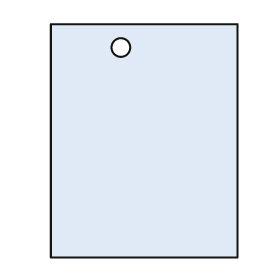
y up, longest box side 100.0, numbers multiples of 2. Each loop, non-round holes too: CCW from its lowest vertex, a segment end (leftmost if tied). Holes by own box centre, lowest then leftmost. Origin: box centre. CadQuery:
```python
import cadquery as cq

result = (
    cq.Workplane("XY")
    .moveTo(-40.0, -50.0)
    .lineTo(40.0, -50.0)
    .lineTo(40.0, 50.0)
    .lineTo(-40.0, 50.0)
    .close()
    .moveTo(-10.0, 40.0)
    .circle(4.0)
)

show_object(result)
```